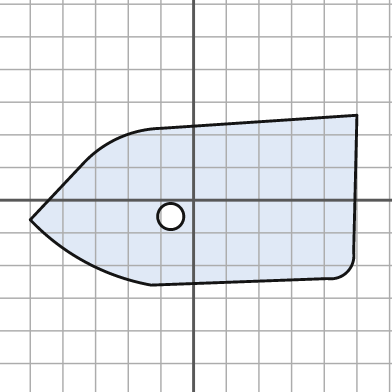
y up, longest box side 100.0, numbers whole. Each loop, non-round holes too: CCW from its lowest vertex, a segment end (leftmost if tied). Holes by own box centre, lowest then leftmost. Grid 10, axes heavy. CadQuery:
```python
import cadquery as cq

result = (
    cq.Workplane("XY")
    .moveTo(-13.0, -26.0)
    .lineTo(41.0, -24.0)
    .threePointArc((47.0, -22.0), (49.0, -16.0))
    .lineTo(50.0, 26.0)
    .lineTo(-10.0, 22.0)
    .threePointArc((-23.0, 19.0), (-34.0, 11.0))
    .lineTo(-50.0, -6.0)
    .threePointArc((-33.0, -19.0), (-13.0, -26.0))
    .close()
    .moveTo(-7.0, -5.0)
    .circle(4.0)
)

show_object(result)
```